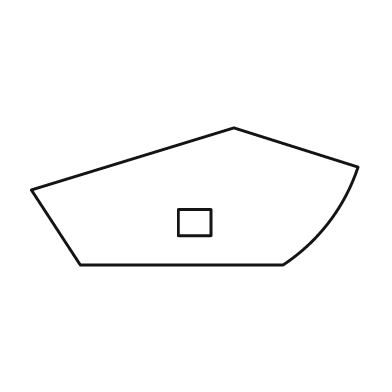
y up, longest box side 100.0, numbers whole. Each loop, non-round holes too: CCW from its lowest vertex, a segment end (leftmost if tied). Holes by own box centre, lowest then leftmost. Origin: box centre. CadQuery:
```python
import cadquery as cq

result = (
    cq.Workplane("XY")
    .moveTo(-35.0, -21.0)
    .lineTo(27.0, -21.0)
    .threePointArc((41.0, -8.0), (50.0, 9.0))
    .lineTo(12.0, 21.0)
    .lineTo(-50.0, 2.0)
    .close()
    .moveTo(-5.0, -12.0)
    .lineTo(5.0, -12.0)
    .lineTo(5.0, -4.0)
    .lineTo(-5.0, -4.0)
    .close()
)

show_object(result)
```